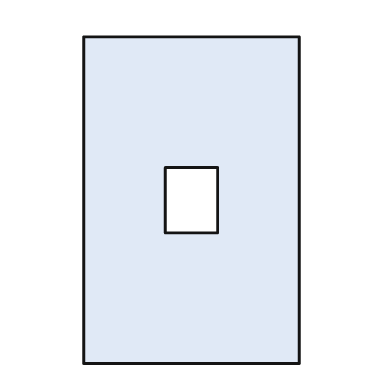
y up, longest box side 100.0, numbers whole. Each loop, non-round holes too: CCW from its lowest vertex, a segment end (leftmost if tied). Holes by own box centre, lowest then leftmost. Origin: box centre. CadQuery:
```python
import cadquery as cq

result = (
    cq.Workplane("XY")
    .moveTo(-33.0, -50.0)
    .lineTo(33.0, -50.0)
    .lineTo(33.0, 50.0)
    .lineTo(-33.0, 50.0)
    .close()
    .moveTo(-8.0, -10.0)
    .lineTo(8.0, -10.0)
    .lineTo(8.0, 10.0)
    .lineTo(-8.0, 10.0)
    .close()
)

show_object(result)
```